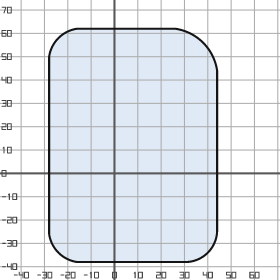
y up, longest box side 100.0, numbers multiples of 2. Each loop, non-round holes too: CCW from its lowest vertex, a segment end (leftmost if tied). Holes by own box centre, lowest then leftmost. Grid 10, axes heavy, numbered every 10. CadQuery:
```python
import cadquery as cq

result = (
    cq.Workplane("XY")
    .moveTo(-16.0, -38.0)
    .lineTo(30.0, -38.0)
    .threePointArc((40.0, -34.0), (44.0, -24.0))
    .lineTo(44.0, 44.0)
    .threePointArc((38.0, 56.0), (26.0, 62.0))
    .lineTo(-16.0, 62.0)
    .threePointArc((-24.0, 58.0), (-28.0, 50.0))
    .lineTo(-28.0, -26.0)
    .threePointArc((-24.0, -34.0), (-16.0, -38.0))
    .close()
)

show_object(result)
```